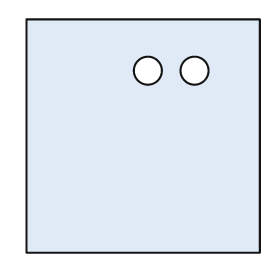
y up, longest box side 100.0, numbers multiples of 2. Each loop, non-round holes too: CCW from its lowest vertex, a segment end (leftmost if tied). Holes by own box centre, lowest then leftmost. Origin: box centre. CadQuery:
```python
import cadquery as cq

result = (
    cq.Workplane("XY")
    .moveTo(-50.0, -50.0)
    .lineTo(50.0, -50.0)
    .lineTo(50.0, 50.0)
    .lineTo(-50.0, 50.0)
    .close()
    .moveTo(2.0, 28.0)
    .circle(6.0)
    .moveTo(22.0, 28.0)
    .circle(6.0)
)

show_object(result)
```